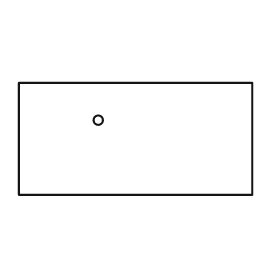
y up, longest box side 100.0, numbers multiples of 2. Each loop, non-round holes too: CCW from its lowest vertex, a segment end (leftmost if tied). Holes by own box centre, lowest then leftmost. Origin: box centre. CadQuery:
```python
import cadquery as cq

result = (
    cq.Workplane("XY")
    .moveTo(-50.0, -24.0)
    .lineTo(50.0, -24.0)
    .lineTo(50.0, 24.0)
    .lineTo(-50.0, 24.0)
    .close()
    .moveTo(-16.0, 8.0)
    .circle(2.0)
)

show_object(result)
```